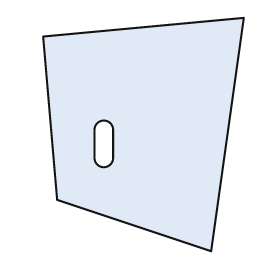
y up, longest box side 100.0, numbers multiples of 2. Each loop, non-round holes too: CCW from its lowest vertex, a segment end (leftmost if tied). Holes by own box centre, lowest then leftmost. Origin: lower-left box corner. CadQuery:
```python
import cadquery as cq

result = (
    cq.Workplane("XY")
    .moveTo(72.0, 0.0)
    .lineTo(86.0, 100.0)
    .lineTo(0.0, 92.0)
    .lineTo(6.0, 22.0)
    .close()
    .moveTo(22.0, 40.0)
    .threePointArc((26.0, 36.0), (30.0, 40.0))
    .lineTo(30.0, 52.0)
    .threePointArc((26.0, 56.0), (22.0, 52.0))
    .close()
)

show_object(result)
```